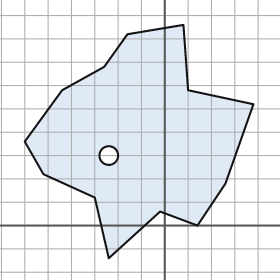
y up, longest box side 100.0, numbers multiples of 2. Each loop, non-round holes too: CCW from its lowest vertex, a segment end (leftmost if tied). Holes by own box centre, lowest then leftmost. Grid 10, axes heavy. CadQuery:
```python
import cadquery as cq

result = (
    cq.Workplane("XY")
    .moveTo(-24.0, -14.0)
    .lineTo(-2.0, 6.0)
    .lineTo(14.0, 0.0)
    .lineTo(26.0, 18.0)
    .lineTo(38.0, 52.0)
    .lineTo(10.0, 58.0)
    .lineTo(8.0, 86.0)
    .lineTo(-16.0, 82.0)
    .lineTo(-26.0, 68.0)
    .lineTo(-44.0, 58.0)
    .lineTo(-60.0, 36.0)
    .lineTo(-52.0, 22.0)
    .lineTo(-30.0, 12.0)
    .close()
    .moveTo(-24.0, 30.0)
    .circle(4.0)
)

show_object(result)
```